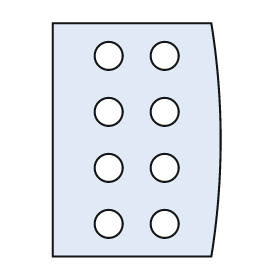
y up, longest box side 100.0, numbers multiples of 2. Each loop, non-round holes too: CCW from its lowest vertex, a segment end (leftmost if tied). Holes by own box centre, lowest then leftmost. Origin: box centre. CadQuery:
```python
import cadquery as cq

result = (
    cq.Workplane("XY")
    .moveTo(-36.0, -50.0)
    .lineTo(32.0, -50.0)
    .threePointArc((36.0, 0.0), (32.0, 50.0))
    .lineTo(-36.0, 50.0)
    .close()
    .moveTo(-12.0, -36.0)
    .circle(6.0)
    .moveTo(12.0, -36.0)
    .circle(6.0)
    .moveTo(-12.0, -12.0)
    .circle(6.0)
    .moveTo(12.0, -12.0)
    .circle(6.0)
    .moveTo(-12.0, 12.0)
    .circle(6.0)
    .moveTo(12.0, 12.0)
    .circle(6.0)
    .moveTo(-12.0, 36.0)
    .circle(6.0)
    .moveTo(12.0, 36.0)
    .circle(6.0)
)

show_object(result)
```